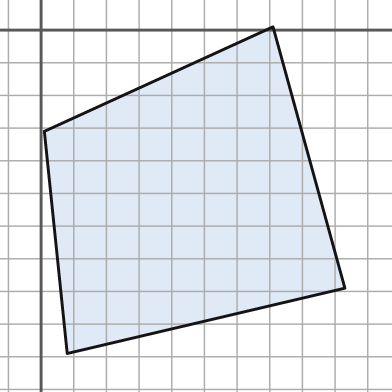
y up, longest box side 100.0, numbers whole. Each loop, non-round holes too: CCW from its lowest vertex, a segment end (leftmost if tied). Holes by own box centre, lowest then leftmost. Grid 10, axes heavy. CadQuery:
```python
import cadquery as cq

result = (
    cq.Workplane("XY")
    .moveTo(8.0, -99.0)
    .lineTo(93.0, -79.0)
    .lineTo(71.0, 1.0)
    .lineTo(1.0, -31.0)
    .close()
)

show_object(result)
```